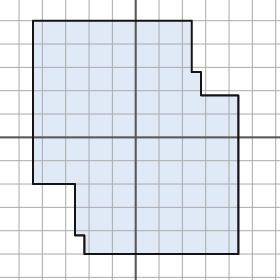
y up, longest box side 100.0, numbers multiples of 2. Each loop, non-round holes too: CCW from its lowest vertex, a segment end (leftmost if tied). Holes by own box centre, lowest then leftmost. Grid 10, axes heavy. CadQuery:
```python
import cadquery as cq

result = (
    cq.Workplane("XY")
    .moveTo(-22.0, -50.0)
    .lineTo(44.0, -50.0)
    .lineTo(44.0, 18.0)
    .lineTo(28.0, 18.0)
    .lineTo(28.0, 28.0)
    .lineTo(24.0, 28.0)
    .lineTo(24.0, 50.0)
    .lineTo(-44.0, 50.0)
    .lineTo(-44.0, -20.0)
    .lineTo(-26.0, -20.0)
    .lineTo(-26.0, -42.0)
    .lineTo(-22.0, -42.0)
    .close()
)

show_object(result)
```